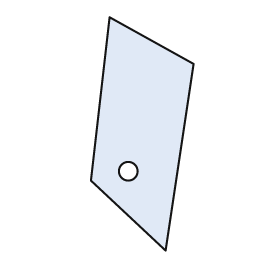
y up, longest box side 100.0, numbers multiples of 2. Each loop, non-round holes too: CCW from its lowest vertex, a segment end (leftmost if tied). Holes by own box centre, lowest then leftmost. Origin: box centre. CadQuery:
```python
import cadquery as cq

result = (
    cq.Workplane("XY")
    .moveTo(10.0, -50.0)
    .lineTo(22.0, 30.0)
    .lineTo(-14.0, 50.0)
    .lineTo(-22.0, -20.0)
    .close()
    .moveTo(-6.0, -16.0)
    .circle(4.0)
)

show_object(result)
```